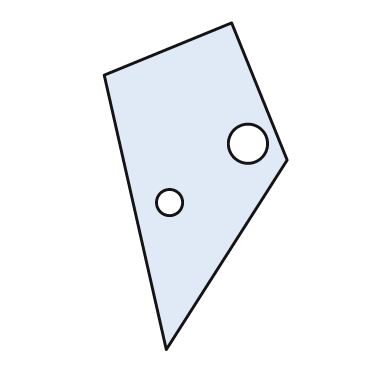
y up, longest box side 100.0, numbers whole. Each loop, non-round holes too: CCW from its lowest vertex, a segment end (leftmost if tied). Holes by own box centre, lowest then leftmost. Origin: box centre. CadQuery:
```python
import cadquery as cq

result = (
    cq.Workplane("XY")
    .moveTo(-9.0, -50.0)
    .lineTo(28.0, 8.0)
    .lineTo(11.0, 50.0)
    .lineTo(-28.0, 34.0)
    .close()
    .moveTo(-8.0, -5.0)
    .circle(4.0)
    .moveTo(16.0, 13.0)
    .circle(6.0)
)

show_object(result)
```